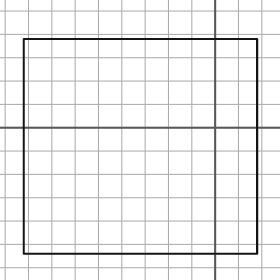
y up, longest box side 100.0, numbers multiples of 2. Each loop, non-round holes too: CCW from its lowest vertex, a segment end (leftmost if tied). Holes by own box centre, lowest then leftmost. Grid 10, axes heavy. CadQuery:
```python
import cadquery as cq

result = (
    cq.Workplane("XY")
    .moveTo(-82.0, -54.0)
    .lineTo(18.0, -54.0)
    .lineTo(18.0, 38.0)
    .lineTo(-82.0, 38.0)
    .close()
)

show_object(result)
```